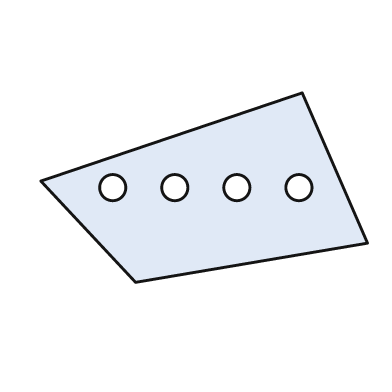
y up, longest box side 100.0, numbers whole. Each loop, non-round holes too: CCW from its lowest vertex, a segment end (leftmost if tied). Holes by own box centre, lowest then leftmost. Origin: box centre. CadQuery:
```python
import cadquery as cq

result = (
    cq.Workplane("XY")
    .moveTo(-21.0, -29.0)
    .lineTo(50.0, -17.0)
    .lineTo(30.0, 29.0)
    .lineTo(-50.0, 2.0)
    .close()
    .moveTo(-28.0, 0.0)
    .circle(4.0)
    .moveTo(-9.0, 0.0)
    .circle(4.0)
    .moveTo(10.0, 0.0)
    .circle(4.0)
    .moveTo(29.0, 0.0)
    .circle(4.0)
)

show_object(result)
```